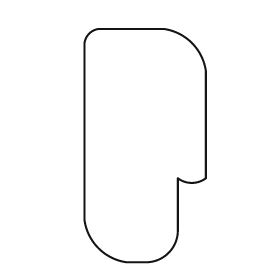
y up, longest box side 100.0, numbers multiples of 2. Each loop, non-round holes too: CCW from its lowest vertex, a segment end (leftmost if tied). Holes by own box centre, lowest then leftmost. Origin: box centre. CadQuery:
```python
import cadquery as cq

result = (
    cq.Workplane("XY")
    .moveTo(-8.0, -50.0)
    .lineTo(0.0, -50.0)
    .threePointArc((10.0, -46.0), (14.0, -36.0))
    .lineTo(14.0, -14.0)
    .threePointArc((20.0, -16.0), (26.0, -14.0))
    .lineTo(26.0, 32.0)
    .threePointArc((20.0, 44.0), (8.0, 50.0))
    .lineTo(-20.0, 50.0)
    .threePointArc((-24.0, 48.0), (-26.0, 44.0))
    .lineTo(-26.0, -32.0)
    .threePointArc((-20.0, -44.0), (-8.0, -50.0))
    .close()
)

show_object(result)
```